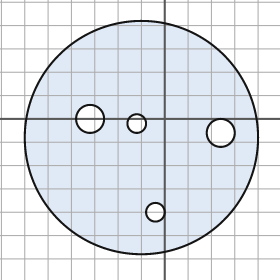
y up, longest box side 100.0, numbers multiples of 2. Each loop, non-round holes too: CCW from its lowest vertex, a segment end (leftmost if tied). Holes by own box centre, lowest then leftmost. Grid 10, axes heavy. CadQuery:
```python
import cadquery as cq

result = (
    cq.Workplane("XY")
    .moveTo(-10.0, -8.0)
    .circle(50.0)
    .moveTo(-4.0, -40.0)
    .circle(4.0)
    .moveTo(24.0, -6.0)
    .circle(6.0)
    .moveTo(-12.0, -2.0)
    .circle(4.0)
    .moveTo(-32.0, 0.0)
    .circle(6.0)
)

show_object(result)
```